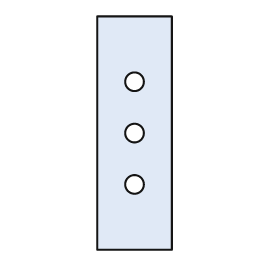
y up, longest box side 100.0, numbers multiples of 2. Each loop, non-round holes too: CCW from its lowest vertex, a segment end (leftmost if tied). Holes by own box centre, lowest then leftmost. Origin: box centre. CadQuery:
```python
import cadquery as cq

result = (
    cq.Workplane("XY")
    .moveTo(-16.0, -50.0)
    .lineTo(16.0, -50.0)
    .lineTo(16.0, 50.0)
    .lineTo(-16.0, 50.0)
    .close()
    .moveTo(0.0, -22.0)
    .circle(4.0)
    .moveTo(0.0, 0.0)
    .circle(4.0)
    .moveTo(0.0, 22.0)
    .circle(4.0)
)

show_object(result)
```